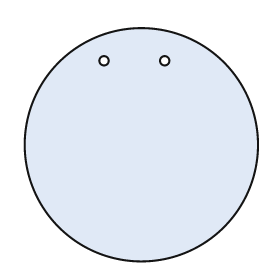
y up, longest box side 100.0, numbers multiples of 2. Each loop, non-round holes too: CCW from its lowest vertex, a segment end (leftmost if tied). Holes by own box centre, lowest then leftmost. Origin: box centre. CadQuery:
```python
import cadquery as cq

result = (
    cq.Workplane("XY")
    .moveTo(0.0, 0.0)
    .circle(50.0)
    .moveTo(-16.0, 36.0)
    .circle(2.0)
    .moveTo(10.0, 36.0)
    .circle(2.0)
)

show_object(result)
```